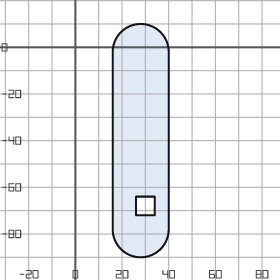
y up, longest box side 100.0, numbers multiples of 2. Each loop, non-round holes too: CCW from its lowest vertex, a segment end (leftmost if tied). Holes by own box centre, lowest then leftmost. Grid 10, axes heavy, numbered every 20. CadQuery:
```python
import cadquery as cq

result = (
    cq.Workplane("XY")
    .moveTo(16.0, -78.0)
    .threePointArc((28.0, -90.0), (40.0, -78.0))
    .lineTo(40.0, -2.0)
    .threePointArc((28.0, 10.0), (16.0, -2.0))
    .close()
    .moveTo(26.0, -72.0)
    .lineTo(34.0, -72.0)
    .lineTo(34.0, -64.0)
    .lineTo(26.0, -64.0)
    .close()
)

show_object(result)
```